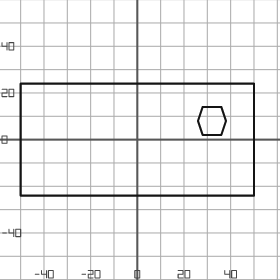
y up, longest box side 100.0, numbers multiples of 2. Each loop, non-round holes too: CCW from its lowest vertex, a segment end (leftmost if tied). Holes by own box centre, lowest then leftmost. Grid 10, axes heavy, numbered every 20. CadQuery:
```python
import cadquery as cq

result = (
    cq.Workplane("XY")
    .moveTo(-50.0, -24.0)
    .lineTo(50.0, -24.0)
    .lineTo(50.0, 24.0)
    .lineTo(-50.0, 24.0)
    .close()
    .moveTo(28.0, 2.0)
    .lineTo(36.0, 2.0)
    .lineTo(38.0, 8.0)
    .lineTo(36.0, 14.0)
    .lineTo(28.0, 14.0)
    .lineTo(26.0, 8.0)
    .close()
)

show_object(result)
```